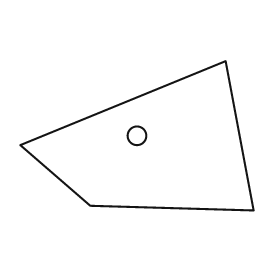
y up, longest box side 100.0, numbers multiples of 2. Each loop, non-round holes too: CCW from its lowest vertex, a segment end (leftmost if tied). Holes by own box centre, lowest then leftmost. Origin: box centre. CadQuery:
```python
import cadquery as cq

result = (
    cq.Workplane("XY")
    .moveTo(50.0, -32.0)
    .lineTo(38.0, 32.0)
    .lineTo(-50.0, -4.0)
    .lineTo(-20.0, -30.0)
    .close()
    .moveTo(0.0, 0.0)
    .circle(4.0)
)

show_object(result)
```